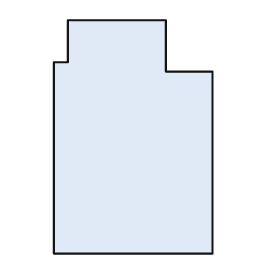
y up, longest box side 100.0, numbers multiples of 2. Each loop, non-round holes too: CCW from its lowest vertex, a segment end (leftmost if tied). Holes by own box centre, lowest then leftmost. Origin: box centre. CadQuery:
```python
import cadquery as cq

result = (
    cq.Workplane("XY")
    .moveTo(-34.0, -50.0)
    .lineTo(34.0, -50.0)
    .lineTo(34.0, 28.0)
    .lineTo(14.0, 28.0)
    .lineTo(14.0, 50.0)
    .lineTo(-28.0, 50.0)
    .lineTo(-28.0, 32.0)
    .lineTo(-34.0, 32.0)
    .close()
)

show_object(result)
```